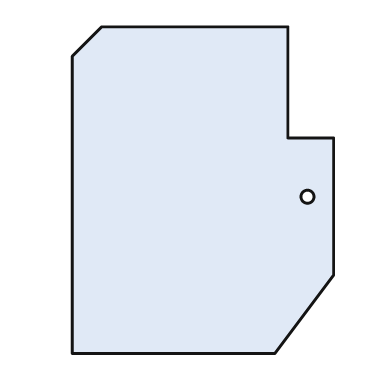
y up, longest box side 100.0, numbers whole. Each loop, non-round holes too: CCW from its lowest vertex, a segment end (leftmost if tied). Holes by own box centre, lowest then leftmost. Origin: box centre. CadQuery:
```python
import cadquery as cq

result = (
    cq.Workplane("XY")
    .moveTo(-40.0, -50.0)
    .lineTo(22.0, -50.0)
    .lineTo(40.0, -26.0)
    .lineTo(40.0, 16.0)
    .lineTo(26.0, 16.0)
    .lineTo(26.0, 50.0)
    .lineTo(-31.0, 50.0)
    .lineTo(-40.0, 41.0)
    .close()
    .moveTo(32.0, -2.0)
    .circle(2.0)
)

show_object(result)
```